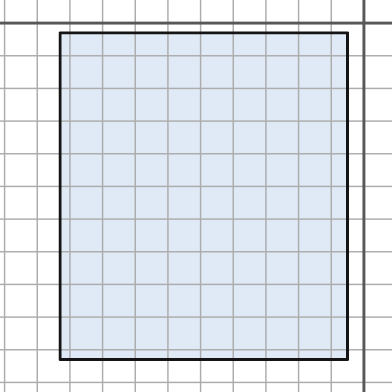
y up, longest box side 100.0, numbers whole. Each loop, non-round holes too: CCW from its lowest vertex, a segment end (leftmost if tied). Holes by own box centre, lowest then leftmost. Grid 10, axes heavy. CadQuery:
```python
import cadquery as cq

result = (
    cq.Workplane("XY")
    .moveTo(-93.0, -103.0)
    .lineTo(-5.0, -103.0)
    .lineTo(-5.0, -3.0)
    .lineTo(-93.0, -3.0)
    .close()
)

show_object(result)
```